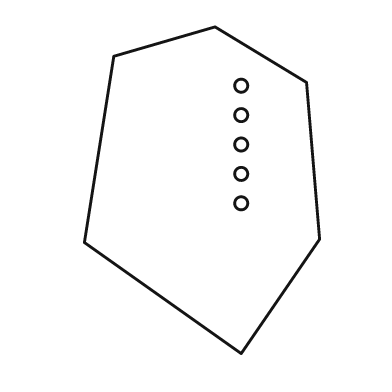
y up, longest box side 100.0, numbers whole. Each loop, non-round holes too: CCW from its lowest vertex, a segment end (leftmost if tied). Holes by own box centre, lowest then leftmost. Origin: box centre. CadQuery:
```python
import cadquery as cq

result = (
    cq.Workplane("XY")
    .moveTo(12.0, -50.0)
    .lineTo(36.0, -15.0)
    .lineTo(32.0, 33.0)
    .lineTo(4.0, 50.0)
    .lineTo(-27.0, 41.0)
    .lineTo(-36.0, -16.0)
    .close()
    .moveTo(12.0, -4.0)
    .circle(2.0)
    .moveTo(12.0, 5.0)
    .circle(2.0)
    .moveTo(12.0, 14.0)
    .circle(2.0)
    .moveTo(12.0, 23.0)
    .circle(2.0)
    .moveTo(12.0, 32.0)
    .circle(2.0)
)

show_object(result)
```